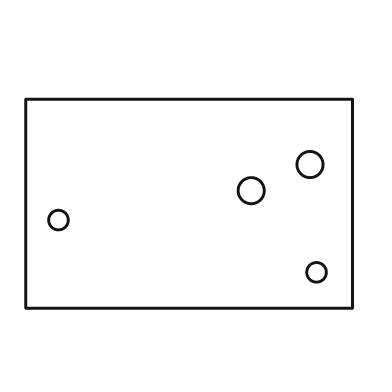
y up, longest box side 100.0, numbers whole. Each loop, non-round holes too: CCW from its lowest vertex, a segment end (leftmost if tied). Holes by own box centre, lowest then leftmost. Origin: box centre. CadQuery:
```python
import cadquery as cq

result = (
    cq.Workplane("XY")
    .moveTo(-50.0, -32.0)
    .lineTo(50.0, -32.0)
    .lineTo(50.0, 32.0)
    .lineTo(-50.0, 32.0)
    .close()
    .moveTo(39.0, -21.0)
    .circle(3.0)
    .moveTo(-40.0, -5.0)
    .circle(3.0)
    .moveTo(19.0, 4.0)
    .circle(4.0)
    .moveTo(37.0, 12.0)
    .circle(4.0)
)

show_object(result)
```